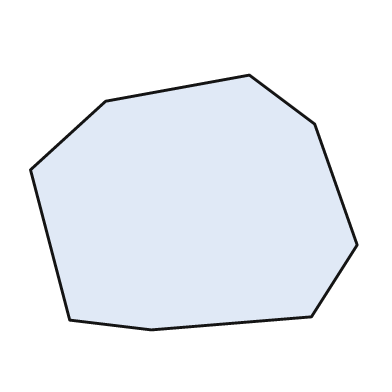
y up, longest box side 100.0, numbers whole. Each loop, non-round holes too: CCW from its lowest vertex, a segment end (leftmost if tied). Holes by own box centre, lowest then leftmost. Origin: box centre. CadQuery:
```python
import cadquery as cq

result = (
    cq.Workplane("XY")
    .moveTo(-13.0, -39.0)
    .lineTo(36.0, -35.0)
    .lineTo(50.0, -13.0)
    .lineTo(37.0, 24.0)
    .lineTo(17.0, 39.0)
    .lineTo(-27.0, 31.0)
    .lineTo(-50.0, 10.0)
    .lineTo(-38.0, -36.0)
    .close()
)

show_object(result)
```